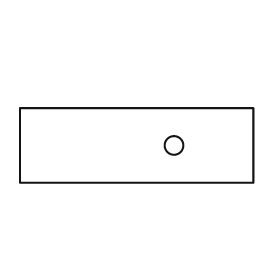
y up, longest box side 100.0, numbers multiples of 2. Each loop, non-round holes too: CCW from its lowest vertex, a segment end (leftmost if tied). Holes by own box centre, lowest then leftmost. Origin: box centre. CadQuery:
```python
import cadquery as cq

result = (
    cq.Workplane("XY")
    .moveTo(-50.0, -16.0)
    .lineTo(50.0, -16.0)
    .lineTo(50.0, 16.0)
    .lineTo(-50.0, 16.0)
    .close()
    .moveTo(16.0, 0.0)
    .circle(4.0)
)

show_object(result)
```